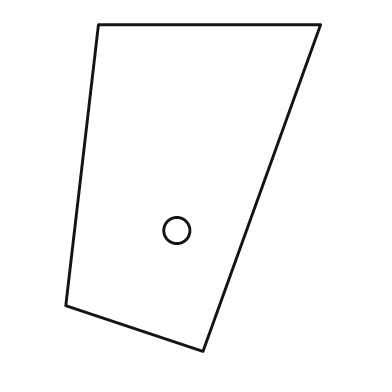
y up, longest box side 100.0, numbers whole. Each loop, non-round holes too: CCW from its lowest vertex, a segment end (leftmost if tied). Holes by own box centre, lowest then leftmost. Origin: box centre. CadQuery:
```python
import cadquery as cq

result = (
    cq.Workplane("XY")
    .moveTo(3.0, -50.0)
    .lineTo(39.0, 50.0)
    .lineTo(-29.0, 50.0)
    .lineTo(-39.0, -36.0)
    .close()
    .moveTo(-5.0, -13.0)
    .circle(4.0)
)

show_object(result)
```